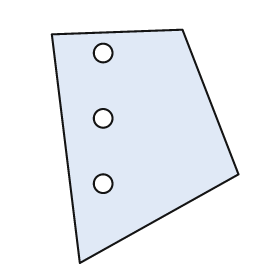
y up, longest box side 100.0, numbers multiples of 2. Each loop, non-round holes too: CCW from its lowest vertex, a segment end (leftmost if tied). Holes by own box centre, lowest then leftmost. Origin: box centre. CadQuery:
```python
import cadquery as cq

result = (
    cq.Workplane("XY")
    .moveTo(-28.0, -50.0)
    .lineTo(40.0, -12.0)
    .lineTo(16.0, 50.0)
    .lineTo(-40.0, 48.0)
    .close()
    .moveTo(-18.0, -16.0)
    .circle(4.0)
    .moveTo(-18.0, 12.0)
    .circle(4.0)
    .moveTo(-18.0, 40.0)
    .circle(4.0)
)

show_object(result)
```